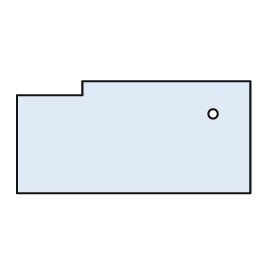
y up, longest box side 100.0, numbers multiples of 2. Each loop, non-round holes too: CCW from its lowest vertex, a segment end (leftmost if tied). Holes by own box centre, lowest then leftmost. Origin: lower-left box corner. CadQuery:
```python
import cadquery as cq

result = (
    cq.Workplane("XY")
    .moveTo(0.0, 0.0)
    .lineTo(100.0, 0.0)
    .lineTo(100.0, 48.0)
    .lineTo(28.0, 48.0)
    .lineTo(28.0, 42.0)
    .lineTo(0.0, 42.0)
    .close()
    .moveTo(84.0, 34.0)
    .circle(2.0)
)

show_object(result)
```